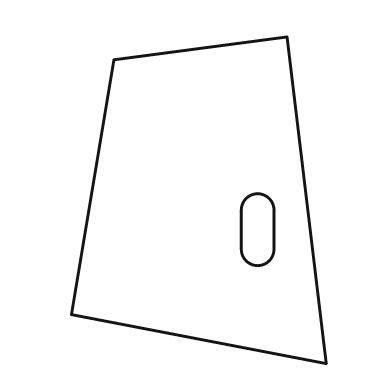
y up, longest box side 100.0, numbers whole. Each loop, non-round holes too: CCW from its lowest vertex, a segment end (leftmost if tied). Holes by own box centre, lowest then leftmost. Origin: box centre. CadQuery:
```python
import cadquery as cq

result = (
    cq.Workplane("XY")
    .moveTo(39.0, -50.0)
    .lineTo(27.0, 50.0)
    .lineTo(-26.0, 43.0)
    .lineTo(-39.0, -35.0)
    .close()
    .moveTo(13.0, -15.0)
    .threePointArc((18.0, -20.0), (23.0, -15.0))
    .lineTo(23.0, -3.0)
    .threePointArc((18.0, 2.0), (13.0, -3.0))
    .close()
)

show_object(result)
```